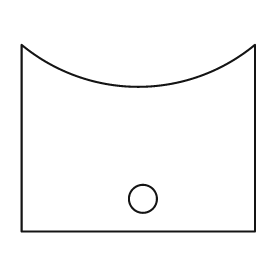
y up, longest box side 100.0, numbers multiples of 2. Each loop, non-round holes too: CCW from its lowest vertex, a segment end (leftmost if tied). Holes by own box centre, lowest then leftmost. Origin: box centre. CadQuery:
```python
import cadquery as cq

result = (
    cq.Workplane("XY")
    .moveTo(-50.0, -40.0)
    .lineTo(50.0, -40.0)
    .lineTo(50.0, 40.0)
    .threePointArc((0.0, 22.0), (-50.0, 40.0))
    .close()
    .moveTo(2.0, -26.0)
    .circle(6.0)
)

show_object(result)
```